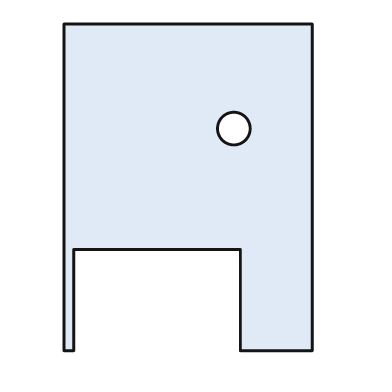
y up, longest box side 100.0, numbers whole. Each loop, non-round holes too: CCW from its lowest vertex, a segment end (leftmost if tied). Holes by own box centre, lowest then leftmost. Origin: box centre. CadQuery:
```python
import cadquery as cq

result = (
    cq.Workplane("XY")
    .moveTo(-38.0, -50.0)
    .lineTo(-35.0, -50.0)
    .lineTo(-35.0, -19.0)
    .lineTo(16.0, -19.0)
    .lineTo(16.0, -50.0)
    .lineTo(38.0, -50.0)
    .lineTo(38.0, 50.0)
    .lineTo(-38.0, 50.0)
    .close()
    .moveTo(14.0, 18.0)
    .circle(5.0)
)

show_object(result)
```